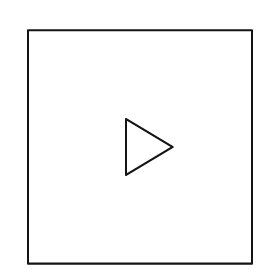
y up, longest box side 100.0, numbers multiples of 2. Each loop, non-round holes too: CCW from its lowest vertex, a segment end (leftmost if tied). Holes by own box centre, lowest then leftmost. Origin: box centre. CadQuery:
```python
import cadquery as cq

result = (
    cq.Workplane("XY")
    .moveTo(-48.0, -50.0)
    .lineTo(48.0, -50.0)
    .lineTo(48.0, 50.0)
    .lineTo(-48.0, 50.0)
    .close()
    .moveTo(-6.0, -12.0)
    .lineTo(14.0, 0.0)
    .lineTo(-6.0, 12.0)
    .close()
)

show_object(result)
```